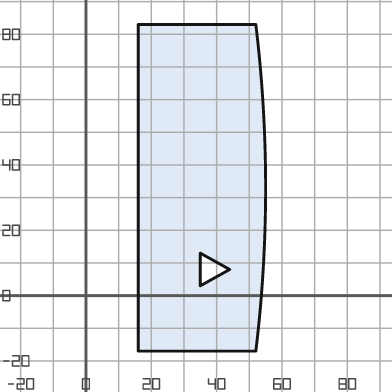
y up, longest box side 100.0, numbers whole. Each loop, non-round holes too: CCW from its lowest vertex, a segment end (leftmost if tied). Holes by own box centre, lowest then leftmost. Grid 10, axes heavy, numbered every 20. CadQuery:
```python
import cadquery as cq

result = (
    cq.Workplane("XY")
    .moveTo(16.0, -17.0)
    .lineTo(52.0, -17.0)
    .threePointArc((55.0, 33.0), (52.0, 83.0))
    .lineTo(16.0, 83.0)
    .close()
    .moveTo(35.0, 3.0)
    .lineTo(44.0, 8.0)
    .lineTo(35.0, 13.0)
    .close()
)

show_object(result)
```